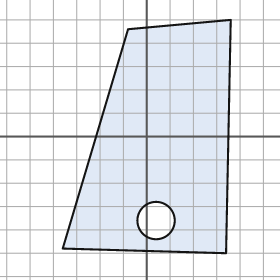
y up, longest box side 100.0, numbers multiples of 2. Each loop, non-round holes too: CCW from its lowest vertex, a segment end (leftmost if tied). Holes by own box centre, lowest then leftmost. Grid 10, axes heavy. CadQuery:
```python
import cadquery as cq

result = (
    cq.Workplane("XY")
    .moveTo(34.0, -50.0)
    .lineTo(36.0, 50.0)
    .lineTo(-8.0, 46.0)
    .lineTo(-36.0, -48.0)
    .close()
    .moveTo(4.0, -36.0)
    .circle(8.0)
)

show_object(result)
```